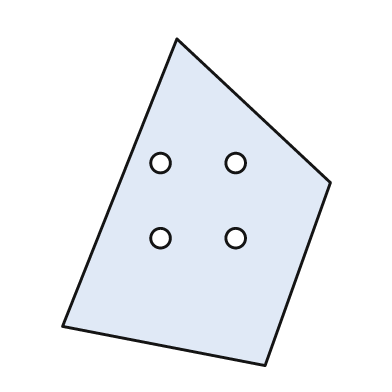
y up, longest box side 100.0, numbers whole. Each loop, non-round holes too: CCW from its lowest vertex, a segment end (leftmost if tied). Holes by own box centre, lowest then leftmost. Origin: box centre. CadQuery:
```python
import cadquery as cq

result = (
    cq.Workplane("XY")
    .moveTo(21.0, -50.0)
    .lineTo(41.0, 6.0)
    .lineTo(-6.0, 50.0)
    .lineTo(-41.0, -38.0)
    .close()
    .moveTo(-11.0, -11.0)
    .circle(3.0)
    .moveTo(12.0, -11.0)
    .circle(3.0)
    .moveTo(-11.0, 12.0)
    .circle(3.0)
    .moveTo(12.0, 12.0)
    .circle(3.0)
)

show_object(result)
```